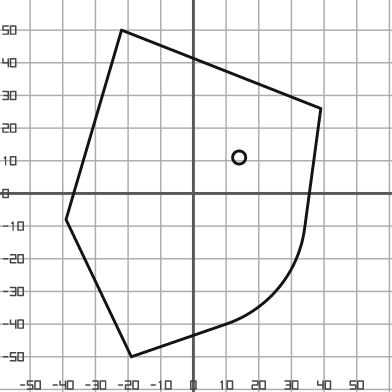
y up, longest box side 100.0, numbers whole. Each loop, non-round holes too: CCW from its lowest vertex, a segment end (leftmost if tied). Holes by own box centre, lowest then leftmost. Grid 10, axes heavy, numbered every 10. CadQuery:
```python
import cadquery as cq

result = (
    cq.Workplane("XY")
    .moveTo(-19.0, -50.0)
    .lineTo(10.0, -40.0)
    .threePointArc((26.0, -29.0), (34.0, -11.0))
    .lineTo(39.0, 26.0)
    .lineTo(-22.0, 50.0)
    .lineTo(-39.0, -8.0)
    .close()
    .moveTo(14.0, 11.0)
    .circle(2.0)
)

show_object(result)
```